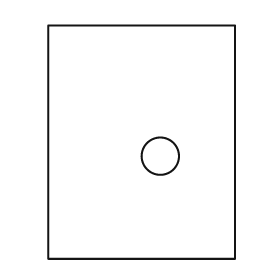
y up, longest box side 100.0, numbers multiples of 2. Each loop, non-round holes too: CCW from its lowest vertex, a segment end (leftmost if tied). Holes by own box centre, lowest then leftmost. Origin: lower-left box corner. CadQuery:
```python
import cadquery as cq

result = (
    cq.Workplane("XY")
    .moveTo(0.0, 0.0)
    .lineTo(80.0, 0.0)
    .lineTo(80.0, 100.0)
    .lineTo(0.0, 100.0)
    .close()
    .moveTo(48.0, 44.0)
    .circle(8.0)
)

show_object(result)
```